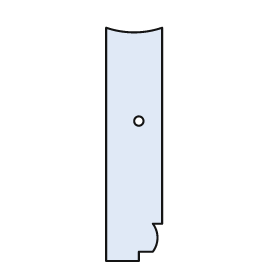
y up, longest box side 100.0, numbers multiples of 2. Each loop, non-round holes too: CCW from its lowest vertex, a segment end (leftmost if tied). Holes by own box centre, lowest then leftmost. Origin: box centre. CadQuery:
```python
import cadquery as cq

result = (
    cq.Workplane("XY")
    .moveTo(-12.0, -50.0)
    .lineTo(2.0, -50.0)
    .lineTo(2.0, -46.0)
    .lineTo(8.0, -46.0)
    .threePointArc((10.0, -40.0), (8.0, -34.0))
    .lineTo(12.0, -34.0)
    .lineTo(12.0, 50.0)
    .threePointArc((0.0, 48.0), (-12.0, 50.0))
    .close()
    .moveTo(2.0, 10.0)
    .circle(2.0)
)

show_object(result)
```